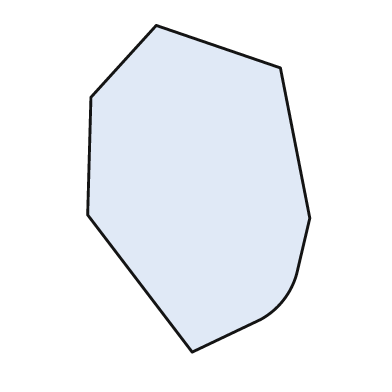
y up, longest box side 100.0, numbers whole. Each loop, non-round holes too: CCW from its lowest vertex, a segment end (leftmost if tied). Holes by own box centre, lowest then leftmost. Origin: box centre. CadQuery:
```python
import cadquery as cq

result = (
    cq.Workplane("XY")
    .moveTo(-2.0, -50.0)
    .lineTo(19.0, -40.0)
    .threePointArc((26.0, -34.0), (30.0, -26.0))
    .lineTo(34.0, -9.0)
    .lineTo(25.0, 37.0)
    .lineTo(-13.0, 50.0)
    .lineTo(-33.0, 28.0)
    .lineTo(-34.0, -8.0)
    .close()
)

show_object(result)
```